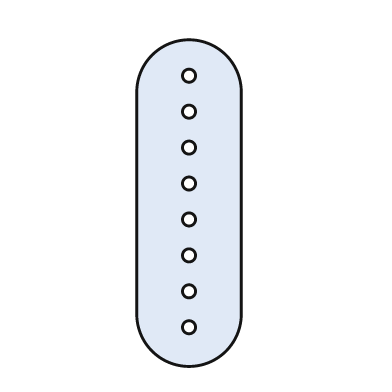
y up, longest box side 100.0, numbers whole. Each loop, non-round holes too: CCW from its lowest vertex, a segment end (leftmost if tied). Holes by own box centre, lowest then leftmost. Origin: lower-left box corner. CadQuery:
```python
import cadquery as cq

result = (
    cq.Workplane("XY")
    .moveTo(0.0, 16.0)
    .threePointArc((16.0, 0.0), (32.0, 16.0))
    .lineTo(32.0, 84.0)
    .threePointArc((16.0, 100.0), (0.0, 84.0))
    .close()
    .moveTo(16.0, 12.0)
    .circle(2.0)
    .moveTo(16.0, 23.0)
    .circle(2.0)
    .moveTo(16.0, 34.0)
    .circle(2.0)
    .moveTo(16.0, 45.0)
    .circle(2.0)
    .moveTo(16.0, 56.0)
    .circle(2.0)
    .moveTo(16.0, 67.0)
    .circle(2.0)
    .moveTo(16.0, 78.0)
    .circle(2.0)
    .moveTo(16.0, 89.0)
    .circle(2.0)
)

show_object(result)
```